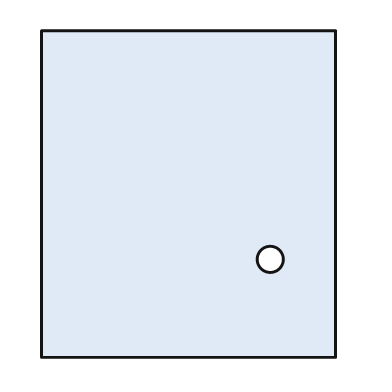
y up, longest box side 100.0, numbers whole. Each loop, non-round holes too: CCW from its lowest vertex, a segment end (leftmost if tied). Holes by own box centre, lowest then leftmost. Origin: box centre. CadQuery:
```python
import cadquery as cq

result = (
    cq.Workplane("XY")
    .moveTo(-45.0, -50.0)
    .lineTo(45.0, -50.0)
    .lineTo(45.0, 50.0)
    .lineTo(-45.0, 50.0)
    .close()
    .moveTo(25.0, -20.0)
    .circle(4.0)
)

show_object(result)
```